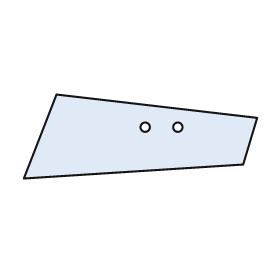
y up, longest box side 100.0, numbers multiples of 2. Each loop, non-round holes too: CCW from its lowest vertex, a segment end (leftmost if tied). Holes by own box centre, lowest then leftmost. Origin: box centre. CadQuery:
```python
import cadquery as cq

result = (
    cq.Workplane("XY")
    .moveTo(-50.0, -18.0)
    .lineTo(44.0, -12.0)
    .lineTo(50.0, 8.0)
    .lineTo(-36.0, 18.0)
    .close()
    .moveTo(2.0, 4.0)
    .circle(2.0)
    .moveTo(16.0, 4.0)
    .circle(2.0)
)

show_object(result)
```